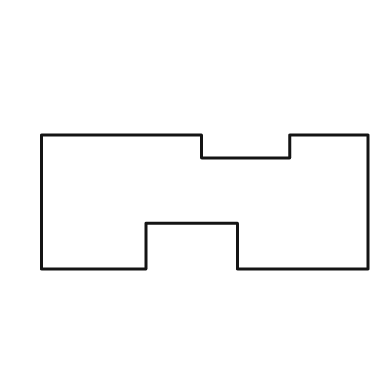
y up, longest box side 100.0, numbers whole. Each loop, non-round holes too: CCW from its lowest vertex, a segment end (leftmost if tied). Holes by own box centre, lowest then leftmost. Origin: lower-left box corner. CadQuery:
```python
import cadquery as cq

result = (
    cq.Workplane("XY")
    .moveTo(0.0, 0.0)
    .lineTo(32.0, 0.0)
    .lineTo(32.0, 14.0)
    .lineTo(60.0, 14.0)
    .lineTo(60.0, 0.0)
    .lineTo(100.0, 0.0)
    .lineTo(100.0, 41.0)
    .lineTo(76.0, 41.0)
    .lineTo(76.0, 34.0)
    .lineTo(49.0, 34.0)
    .lineTo(49.0, 41.0)
    .lineTo(0.0, 41.0)
    .close()
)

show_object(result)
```